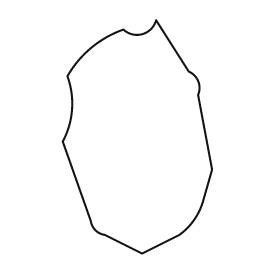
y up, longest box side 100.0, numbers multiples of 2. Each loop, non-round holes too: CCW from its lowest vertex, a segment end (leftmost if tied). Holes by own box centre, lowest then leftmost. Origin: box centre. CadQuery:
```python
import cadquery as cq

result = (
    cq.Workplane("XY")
    .moveTo(2.0, -50.0)
    .lineTo(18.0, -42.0)
    .threePointArc((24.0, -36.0), (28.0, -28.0))
    .lineTo(32.0, -14.0)
    .lineTo(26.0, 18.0)
    .threePointArc((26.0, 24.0), (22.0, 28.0))
    .lineTo(8.0, 50.0)
    .threePointArc((2.0, 44.0), (-6.0, 46.0))
    .threePointArc((-20.0, 38.0), (-30.0, 26.0))
    .threePointArc((-28.0, 12.0), (-32.0, -2.0))
    .lineTo(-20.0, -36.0)
    .threePointArc((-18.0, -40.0), (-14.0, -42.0))
    .close()
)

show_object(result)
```